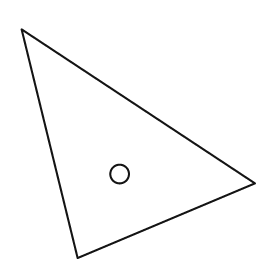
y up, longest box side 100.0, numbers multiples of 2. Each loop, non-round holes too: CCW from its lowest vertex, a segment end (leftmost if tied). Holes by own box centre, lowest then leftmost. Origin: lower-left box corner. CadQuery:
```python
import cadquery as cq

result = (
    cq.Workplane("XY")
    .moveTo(24.0, 0.0)
    .lineTo(100.0, 32.0)
    .lineTo(0.0, 98.0)
    .close()
    .moveTo(42.0, 36.0)
    .circle(4.0)
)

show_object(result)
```